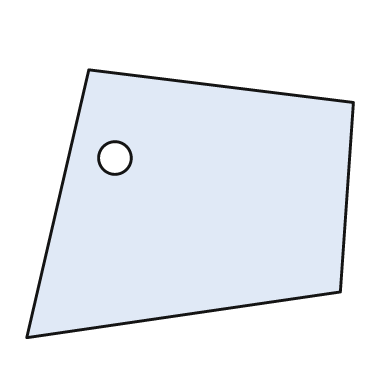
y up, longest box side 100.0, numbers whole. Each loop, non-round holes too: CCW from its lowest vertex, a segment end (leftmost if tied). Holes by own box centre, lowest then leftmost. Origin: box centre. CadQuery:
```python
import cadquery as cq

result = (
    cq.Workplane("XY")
    .moveTo(-50.0, -41.0)
    .lineTo(46.0, -27.0)
    .lineTo(50.0, 31.0)
    .lineTo(-31.0, 41.0)
    .close()
    .moveTo(-23.0, 14.0)
    .circle(5.0)
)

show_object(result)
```